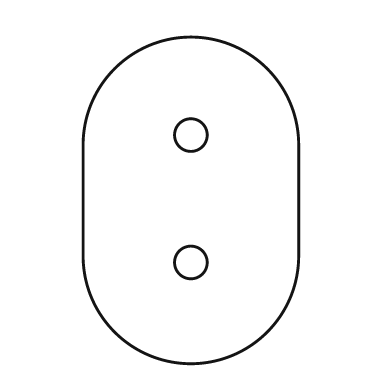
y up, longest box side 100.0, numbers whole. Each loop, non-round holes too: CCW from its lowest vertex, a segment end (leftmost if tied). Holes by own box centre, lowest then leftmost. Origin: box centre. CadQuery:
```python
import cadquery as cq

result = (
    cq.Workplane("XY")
    .moveTo(-33.0, -17.0)
    .threePointArc((0.0, -50.0), (33.0, -17.0))
    .lineTo(33.0, 17.0)
    .threePointArc((0.0, 50.0), (-33.0, 17.0))
    .close()
    .moveTo(0.0, -19.0)
    .circle(5.0)
    .moveTo(0.0, 20.0)
    .circle(5.0)
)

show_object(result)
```